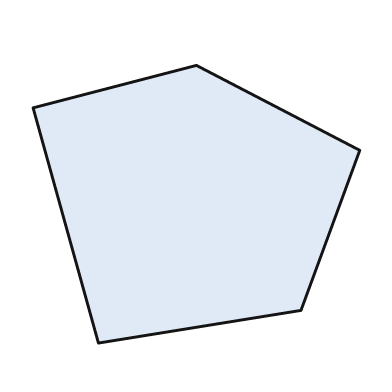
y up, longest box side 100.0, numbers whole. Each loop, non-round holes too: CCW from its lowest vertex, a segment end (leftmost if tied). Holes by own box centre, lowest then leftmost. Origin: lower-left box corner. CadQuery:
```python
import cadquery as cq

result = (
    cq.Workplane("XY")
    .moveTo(20.0, 0.0)
    .lineTo(82.0, 10.0)
    .lineTo(100.0, 59.0)
    .lineTo(50.0, 85.0)
    .lineTo(0.0, 72.0)
    .close()
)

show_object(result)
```